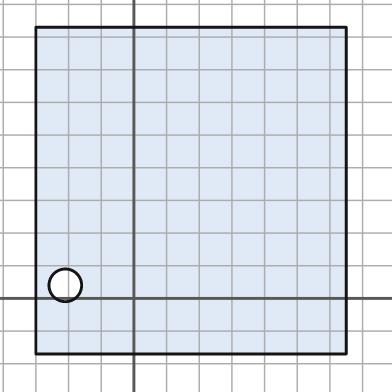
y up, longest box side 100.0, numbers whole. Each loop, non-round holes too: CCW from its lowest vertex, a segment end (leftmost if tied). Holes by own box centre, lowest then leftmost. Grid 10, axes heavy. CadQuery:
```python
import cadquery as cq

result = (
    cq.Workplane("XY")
    .moveTo(-30.0, -17.0)
    .lineTo(65.0, -17.0)
    .lineTo(65.0, 83.0)
    .lineTo(-30.0, 83.0)
    .close()
    .moveTo(-21.0, 4.0)
    .circle(5.0)
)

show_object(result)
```